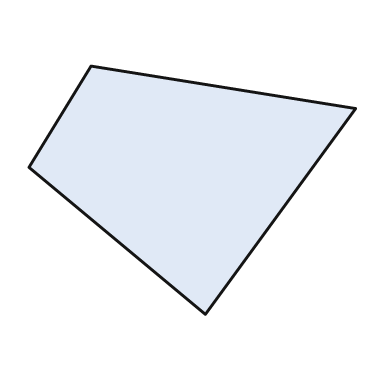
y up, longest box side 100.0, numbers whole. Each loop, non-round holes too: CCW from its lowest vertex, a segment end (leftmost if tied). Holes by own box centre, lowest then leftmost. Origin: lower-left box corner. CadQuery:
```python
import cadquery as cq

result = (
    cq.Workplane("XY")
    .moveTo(54.0, 0.0)
    .lineTo(100.0, 63.0)
    .lineTo(19.0, 76.0)
    .lineTo(0.0, 45.0)
    .close()
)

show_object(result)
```